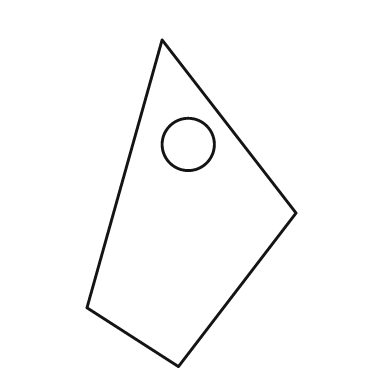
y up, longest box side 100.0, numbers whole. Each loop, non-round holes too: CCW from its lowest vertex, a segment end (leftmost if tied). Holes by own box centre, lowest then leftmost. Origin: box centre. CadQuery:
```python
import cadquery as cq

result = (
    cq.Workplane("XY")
    .moveTo(-4.0, -50.0)
    .lineTo(32.0, -3.0)
    .lineTo(-9.0, 50.0)
    .lineTo(-32.0, -32.0)
    .close()
    .moveTo(-1.0, 18.0)
    .circle(8.0)
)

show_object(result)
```